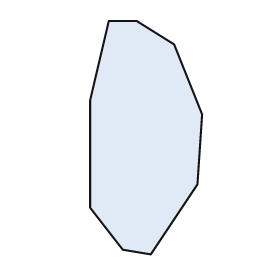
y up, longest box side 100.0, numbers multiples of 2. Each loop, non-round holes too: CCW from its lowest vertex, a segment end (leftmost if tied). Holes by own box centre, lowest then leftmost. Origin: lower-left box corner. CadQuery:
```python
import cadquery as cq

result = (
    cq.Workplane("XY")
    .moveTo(26.0, 0.0)
    .lineTo(46.0, 30.0)
    .lineTo(48.0, 60.0)
    .lineTo(36.0, 90.0)
    .lineTo(20.0, 100.0)
    .lineTo(8.0, 100.0)
    .lineTo(0.0, 66.0)
    .lineTo(0.0, 20.0)
    .lineTo(14.0, 2.0)
    .close()
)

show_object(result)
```